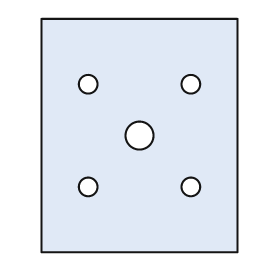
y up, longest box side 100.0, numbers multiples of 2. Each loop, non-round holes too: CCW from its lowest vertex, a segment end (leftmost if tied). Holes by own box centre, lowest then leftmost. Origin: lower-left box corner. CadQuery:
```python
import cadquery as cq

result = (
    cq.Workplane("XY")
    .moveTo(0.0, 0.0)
    .lineTo(84.0, 0.0)
    .lineTo(84.0, 100.0)
    .lineTo(0.0, 100.0)
    .close()
    .moveTo(20.0, 28.0)
    .circle(4.0)
    .moveTo(64.0, 28.0)
    .circle(4.0)
    .moveTo(42.0, 50.0)
    .circle(6.0)
    .moveTo(20.0, 72.0)
    .circle(4.0)
    .moveTo(64.0, 72.0)
    .circle(4.0)
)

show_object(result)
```